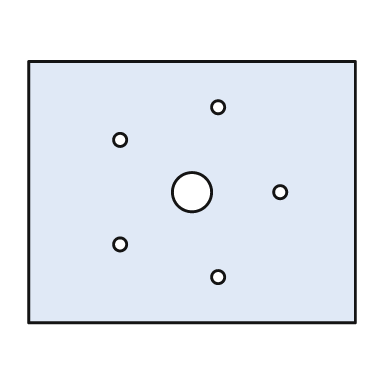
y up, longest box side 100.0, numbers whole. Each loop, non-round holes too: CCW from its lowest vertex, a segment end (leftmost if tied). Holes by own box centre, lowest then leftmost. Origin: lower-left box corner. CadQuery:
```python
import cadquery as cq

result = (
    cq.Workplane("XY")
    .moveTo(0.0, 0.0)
    .lineTo(100.0, 0.0)
    .lineTo(100.0, 80.0)
    .lineTo(0.0, 80.0)
    .close()
    .moveTo(58.0, 14.0)
    .circle(2.0)
    .moveTo(28.0, 24.0)
    .circle(2.0)
    .moveTo(50.0, 40.0)
    .circle(6.0)
    .moveTo(77.0, 40.0)
    .circle(2.0)
    .moveTo(28.0, 56.0)
    .circle(2.0)
    .moveTo(58.0, 66.0)
    .circle(2.0)
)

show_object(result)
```